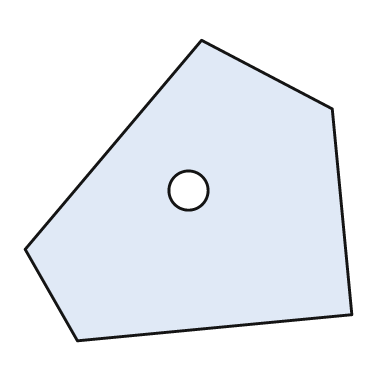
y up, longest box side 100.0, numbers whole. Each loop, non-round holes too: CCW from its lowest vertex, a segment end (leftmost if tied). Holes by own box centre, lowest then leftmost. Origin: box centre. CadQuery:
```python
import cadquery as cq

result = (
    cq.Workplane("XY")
    .moveTo(-34.0, -46.0)
    .lineTo(50.0, -38.0)
    .lineTo(44.0, 25.0)
    .lineTo(4.0, 46.0)
    .lineTo(-50.0, -18.0)
    .close()
    .moveTo(0.0, 0.0)
    .circle(6.0)
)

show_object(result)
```